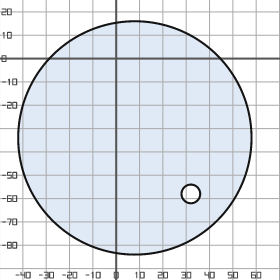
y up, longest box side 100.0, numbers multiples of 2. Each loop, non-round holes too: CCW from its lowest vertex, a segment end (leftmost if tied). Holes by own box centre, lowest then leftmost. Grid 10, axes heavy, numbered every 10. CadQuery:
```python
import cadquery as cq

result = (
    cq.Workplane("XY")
    .moveTo(8.0, -34.0)
    .circle(50.0)
    .moveTo(32.0, -58.0)
    .circle(4.0)
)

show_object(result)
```